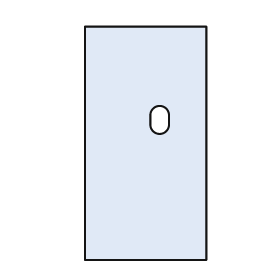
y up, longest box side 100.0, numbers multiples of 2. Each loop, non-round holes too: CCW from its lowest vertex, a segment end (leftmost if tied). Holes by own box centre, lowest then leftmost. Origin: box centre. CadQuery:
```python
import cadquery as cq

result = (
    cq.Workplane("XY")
    .moveTo(-26.0, -50.0)
    .lineTo(26.0, -50.0)
    .lineTo(26.0, 50.0)
    .lineTo(-26.0, 50.0)
    .close()
    .moveTo(2.0, 8.0)
    .threePointArc((6.0, 4.0), (10.0, 8.0))
    .lineTo(10.0, 12.0)
    .threePointArc((6.0, 16.0), (2.0, 12.0))
    .close()
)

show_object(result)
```